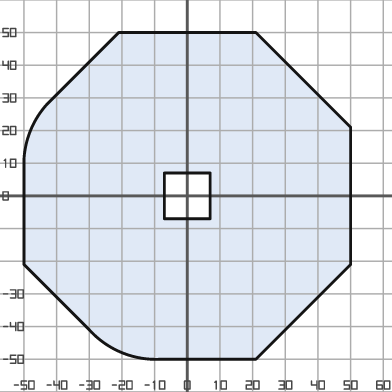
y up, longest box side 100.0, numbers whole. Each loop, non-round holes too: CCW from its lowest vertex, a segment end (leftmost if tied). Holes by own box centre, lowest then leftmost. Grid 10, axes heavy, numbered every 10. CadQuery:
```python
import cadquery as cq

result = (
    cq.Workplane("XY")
    .moveTo(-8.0, -50.0)
    .lineTo(21.0, -50.0)
    .lineTo(50.0, -21.0)
    .lineTo(50.0, 21.0)
    .lineTo(21.0, 50.0)
    .lineTo(-21.0, 50.0)
    .lineTo(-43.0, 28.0)
    .threePointArc((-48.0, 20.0), (-50.0, 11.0))
    .lineTo(-50.0, -21.0)
    .lineTo(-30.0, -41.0)
    .threePointArc((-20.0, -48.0), (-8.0, -50.0))
    .close()
    .moveTo(-7.0, -7.0)
    .lineTo(7.0, -7.0)
    .lineTo(7.0, 7.0)
    .lineTo(-7.0, 7.0)
    .close()
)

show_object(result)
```